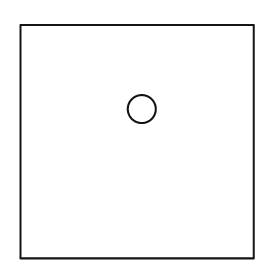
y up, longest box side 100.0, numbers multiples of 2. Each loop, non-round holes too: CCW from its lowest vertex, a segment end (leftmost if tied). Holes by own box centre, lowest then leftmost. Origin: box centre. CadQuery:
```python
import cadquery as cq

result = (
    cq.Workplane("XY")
    .moveTo(-50.0, -50.0)
    .lineTo(50.0, -50.0)
    .lineTo(50.0, 50.0)
    .lineTo(-50.0, 50.0)
    .close()
    .moveTo(2.0, 14.0)
    .circle(6.0)
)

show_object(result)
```